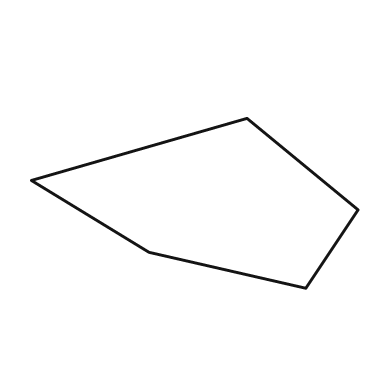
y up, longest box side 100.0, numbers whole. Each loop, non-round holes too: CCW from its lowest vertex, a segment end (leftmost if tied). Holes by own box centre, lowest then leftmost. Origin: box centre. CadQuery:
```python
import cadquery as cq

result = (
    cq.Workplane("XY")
    .moveTo(34.0, -26.0)
    .lineTo(50.0, -2.0)
    .lineTo(16.0, 26.0)
    .lineTo(-50.0, 7.0)
    .lineTo(-14.0, -15.0)
    .close()
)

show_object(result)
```